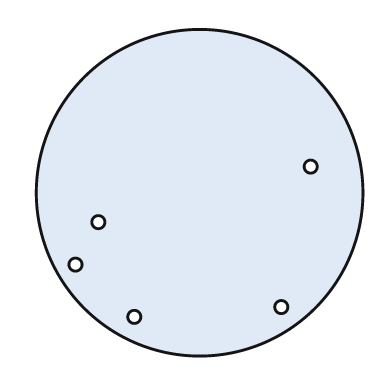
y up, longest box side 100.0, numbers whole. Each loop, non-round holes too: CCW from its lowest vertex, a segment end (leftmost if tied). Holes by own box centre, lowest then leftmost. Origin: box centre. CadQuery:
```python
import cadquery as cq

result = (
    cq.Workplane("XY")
    .moveTo(0.0, 0.0)
    .circle(50.0)
    .moveTo(-20.0, -38.0)
    .circle(2.0)
    .moveTo(25.0, -35.0)
    .circle(2.0)
    .moveTo(-38.0, -22.0)
    .circle(2.0)
    .moveTo(-31.0, -9.0)
    .circle(2.0)
    .moveTo(34.0, 8.0)
    .circle(2.0)
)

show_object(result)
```